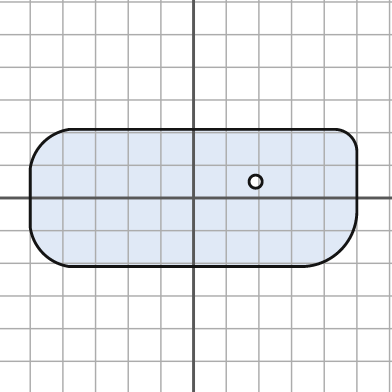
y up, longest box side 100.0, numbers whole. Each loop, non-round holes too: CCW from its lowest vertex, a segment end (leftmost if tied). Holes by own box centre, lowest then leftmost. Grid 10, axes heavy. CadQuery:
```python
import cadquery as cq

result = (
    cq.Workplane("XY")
    .moveTo(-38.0, -21.0)
    .lineTo(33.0, -21.0)
    .threePointArc((45.0, -16.0), (50.0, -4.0))
    .lineTo(50.0, 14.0)
    .threePointArc((48.0, 19.0), (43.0, 21.0))
    .lineTo(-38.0, 21.0)
    .threePointArc((-46.0, 17.0), (-50.0, 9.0))
    .lineTo(-50.0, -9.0)
    .threePointArc((-46.0, -17.0), (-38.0, -21.0))
    .close()
    .moveTo(19.0, 5.0)
    .circle(2.0)
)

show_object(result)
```